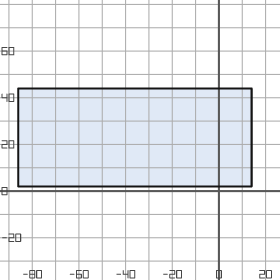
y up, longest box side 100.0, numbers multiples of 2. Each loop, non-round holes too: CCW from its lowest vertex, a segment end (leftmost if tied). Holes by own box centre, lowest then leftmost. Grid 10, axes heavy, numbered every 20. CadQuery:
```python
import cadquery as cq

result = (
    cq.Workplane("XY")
    .moveTo(-86.0, 2.0)
    .lineTo(14.0, 2.0)
    .lineTo(14.0, 44.0)
    .lineTo(-86.0, 44.0)
    .close()
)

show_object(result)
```